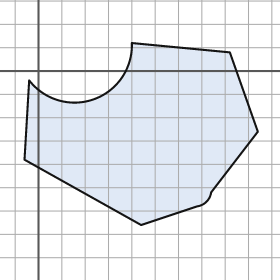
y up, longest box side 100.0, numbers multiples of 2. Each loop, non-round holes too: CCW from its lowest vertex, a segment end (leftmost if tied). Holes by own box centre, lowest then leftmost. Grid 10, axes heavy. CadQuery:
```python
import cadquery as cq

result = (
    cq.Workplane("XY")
    .moveTo(44.0, -66.0)
    .lineTo(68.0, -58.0)
    .threePointArc((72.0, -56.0), (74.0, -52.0))
    .lineTo(94.0, -26.0)
    .lineTo(82.0, 8.0)
    .lineTo(40.0, 12.0)
    .threePointArc((24.0, -12.0), (-4.0, -4.0))
    .lineTo(-6.0, -38.0)
    .close()
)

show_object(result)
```